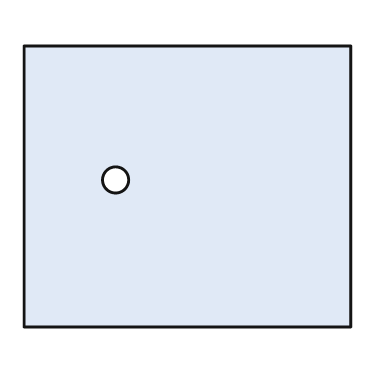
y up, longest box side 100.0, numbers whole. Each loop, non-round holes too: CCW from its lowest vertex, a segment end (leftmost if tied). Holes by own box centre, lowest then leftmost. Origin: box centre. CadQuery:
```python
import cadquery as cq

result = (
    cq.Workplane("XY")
    .moveTo(-50.0, -43.0)
    .lineTo(50.0, -43.0)
    .lineTo(50.0, 43.0)
    .lineTo(-50.0, 43.0)
    .close()
    .moveTo(-22.0, 2.0)
    .circle(4.0)
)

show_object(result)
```